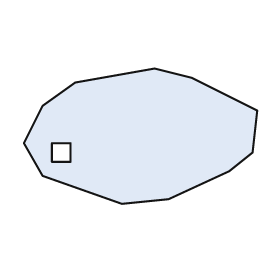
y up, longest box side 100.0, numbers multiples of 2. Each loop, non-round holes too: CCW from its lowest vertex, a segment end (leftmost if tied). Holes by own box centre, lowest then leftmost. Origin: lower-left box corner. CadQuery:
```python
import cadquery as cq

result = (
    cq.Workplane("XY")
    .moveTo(42.0, 0.0)
    .lineTo(62.0, 2.0)
    .lineTo(88.0, 14.0)
    .lineTo(98.0, 22.0)
    .lineTo(100.0, 40.0)
    .lineTo(72.0, 54.0)
    .lineTo(56.0, 58.0)
    .lineTo(22.0, 52.0)
    .lineTo(8.0, 42.0)
    .lineTo(0.0, 26.0)
    .lineTo(8.0, 12.0)
    .close()
    .moveTo(12.0, 18.0)
    .lineTo(20.0, 18.0)
    .lineTo(20.0, 26.0)
    .lineTo(12.0, 26.0)
    .close()
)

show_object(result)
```